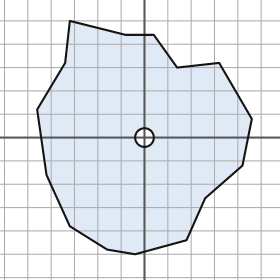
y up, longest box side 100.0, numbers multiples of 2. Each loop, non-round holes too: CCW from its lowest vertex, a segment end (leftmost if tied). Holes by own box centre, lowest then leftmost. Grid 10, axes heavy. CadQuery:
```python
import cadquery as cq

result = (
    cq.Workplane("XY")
    .moveTo(-4.0, -50.0)
    .lineTo(18.0, -44.0)
    .lineTo(26.0, -26.0)
    .lineTo(42.0, -12.0)
    .lineTo(46.0, 8.0)
    .lineTo(32.0, 32.0)
    .lineTo(14.0, 30.0)
    .lineTo(4.0, 44.0)
    .lineTo(-8.0, 44.0)
    .lineTo(-32.0, 50.0)
    .lineTo(-34.0, 32.0)
    .lineTo(-46.0, 12.0)
    .lineTo(-42.0, -16.0)
    .lineTo(-32.0, -38.0)
    .lineTo(-16.0, -48.0)
    .close()
    .moveTo(0.0, 0.0)
    .circle(4.0)
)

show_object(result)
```